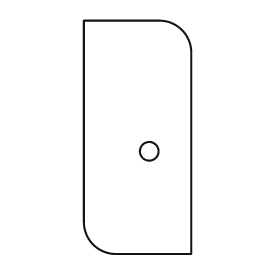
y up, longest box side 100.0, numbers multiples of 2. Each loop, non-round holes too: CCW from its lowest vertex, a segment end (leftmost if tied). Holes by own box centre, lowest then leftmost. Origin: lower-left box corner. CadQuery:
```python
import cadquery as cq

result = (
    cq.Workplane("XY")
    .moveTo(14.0, 0.0)
    .lineTo(46.0, 0.0)
    .lineTo(46.0, 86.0)
    .threePointArc((42.0, 96.0), (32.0, 100.0))
    .lineTo(0.0, 100.0)
    .lineTo(0.0, 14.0)
    .threePointArc((4.0, 4.0), (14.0, 0.0))
    .close()
    .moveTo(28.0, 44.0)
    .circle(4.0)
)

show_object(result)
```